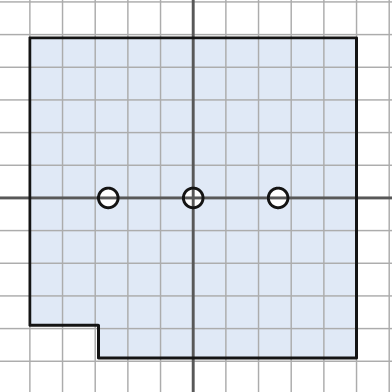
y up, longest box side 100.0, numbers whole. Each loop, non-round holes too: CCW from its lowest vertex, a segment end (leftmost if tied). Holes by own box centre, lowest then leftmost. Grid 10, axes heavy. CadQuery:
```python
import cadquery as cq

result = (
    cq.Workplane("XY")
    .moveTo(-29.0, -49.0)
    .lineTo(50.0, -49.0)
    .lineTo(50.0, 49.0)
    .lineTo(-50.0, 49.0)
    .lineTo(-50.0, -39.0)
    .lineTo(-29.0, -39.0)
    .close()
    .moveTo(-26.0, 0.0)
    .circle(3.0)
    .moveTo(0.0, 0.0)
    .circle(3.0)
    .moveTo(26.0, 0.0)
    .circle(3.0)
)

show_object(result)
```